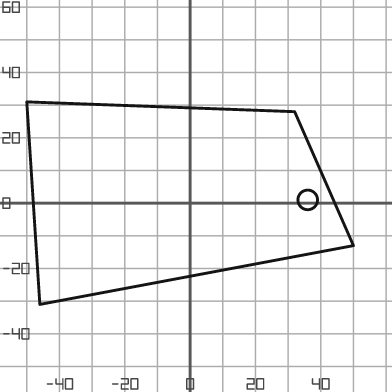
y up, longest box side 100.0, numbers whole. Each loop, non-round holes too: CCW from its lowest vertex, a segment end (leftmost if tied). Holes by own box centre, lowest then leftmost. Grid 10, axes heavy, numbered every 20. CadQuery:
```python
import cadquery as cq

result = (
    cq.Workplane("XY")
    .moveTo(-46.0, -31.0)
    .lineTo(50.0, -13.0)
    .lineTo(32.0, 28.0)
    .lineTo(-50.0, 31.0)
    .close()
    .moveTo(36.0, 1.0)
    .circle(3.0)
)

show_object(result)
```